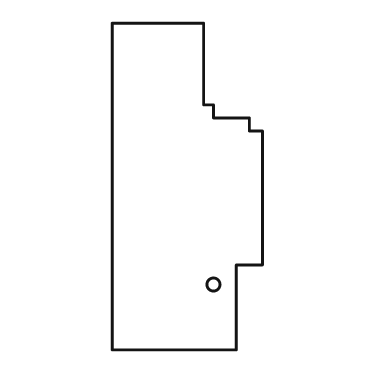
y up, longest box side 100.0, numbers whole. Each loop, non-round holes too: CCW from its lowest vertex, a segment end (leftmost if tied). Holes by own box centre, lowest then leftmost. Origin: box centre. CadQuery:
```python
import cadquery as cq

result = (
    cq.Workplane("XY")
    .moveTo(-23.0, -50.0)
    .lineTo(15.0, -50.0)
    .lineTo(15.0, -24.0)
    .lineTo(23.0, -24.0)
    .lineTo(23.0, 17.0)
    .lineTo(19.0, 17.0)
    .lineTo(19.0, 21.0)
    .lineTo(8.0, 21.0)
    .lineTo(8.0, 25.0)
    .lineTo(5.0, 25.0)
    .lineTo(5.0, 50.0)
    .lineTo(-23.0, 50.0)
    .close()
    .moveTo(8.0, -30.0)
    .circle(2.0)
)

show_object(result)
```